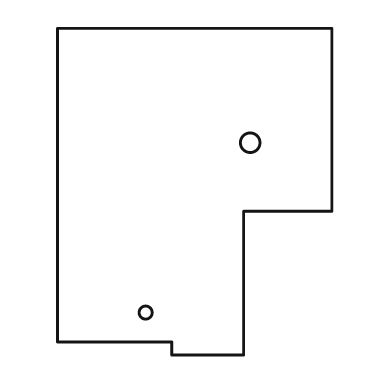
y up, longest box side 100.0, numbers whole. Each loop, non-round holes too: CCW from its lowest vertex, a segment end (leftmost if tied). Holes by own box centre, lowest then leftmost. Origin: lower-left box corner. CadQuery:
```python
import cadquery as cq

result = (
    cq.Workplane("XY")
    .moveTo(35.0, 0.0)
    .lineTo(57.0, 0.0)
    .lineTo(57.0, 44.0)
    .lineTo(84.0, 44.0)
    .lineTo(84.0, 100.0)
    .lineTo(0.0, 100.0)
    .lineTo(0.0, 4.0)
    .lineTo(35.0, 4.0)
    .close()
    .moveTo(27.0, 13.0)
    .circle(2.0)
    .moveTo(59.0, 65.0)
    .circle(3.0)
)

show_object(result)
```